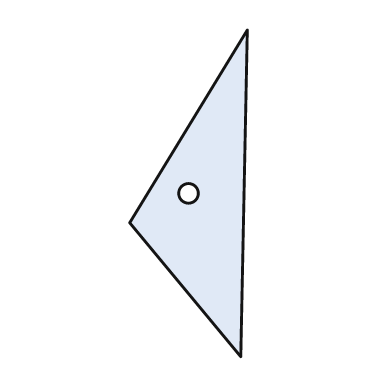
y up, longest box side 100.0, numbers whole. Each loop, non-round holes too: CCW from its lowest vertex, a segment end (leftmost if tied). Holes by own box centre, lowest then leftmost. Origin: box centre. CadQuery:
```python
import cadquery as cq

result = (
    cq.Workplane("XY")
    .moveTo(16.0, -50.0)
    .lineTo(18.0, 50.0)
    .lineTo(-18.0, -9.0)
    .close()
    .moveTo(0.0, 0.0)
    .circle(3.0)
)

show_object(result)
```